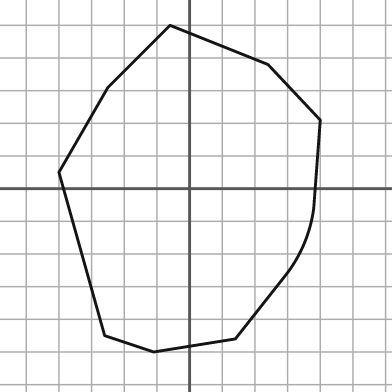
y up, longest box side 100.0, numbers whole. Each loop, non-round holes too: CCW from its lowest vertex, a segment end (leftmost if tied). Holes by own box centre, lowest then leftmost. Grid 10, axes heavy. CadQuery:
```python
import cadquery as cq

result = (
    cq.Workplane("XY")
    .moveTo(-11.0, -50.0)
    .lineTo(14.0, -46.0)
    .lineTo(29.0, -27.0)
    .threePointArc((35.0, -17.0), (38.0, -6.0))
    .lineTo(40.0, 21.0)
    .lineTo(24.0, 38.0)
    .lineTo(-6.0, 50.0)
    .lineTo(-25.0, 31.0)
    .lineTo(-40.0, 5.0)
    .lineTo(-26.0, -45.0)
    .close()
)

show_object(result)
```